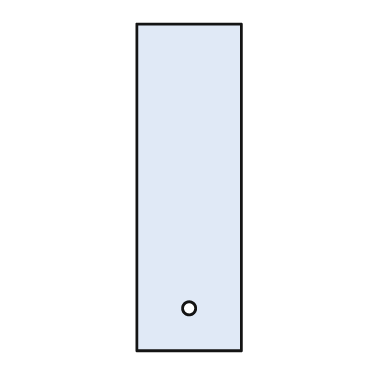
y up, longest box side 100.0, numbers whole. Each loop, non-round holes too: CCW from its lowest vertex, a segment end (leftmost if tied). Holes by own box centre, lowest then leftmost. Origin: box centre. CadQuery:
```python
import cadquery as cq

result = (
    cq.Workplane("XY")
    .moveTo(-16.0, -50.0)
    .lineTo(16.0, -50.0)
    .lineTo(16.0, 50.0)
    .lineTo(-16.0, 50.0)
    .close()
    .moveTo(0.0, -37.0)
    .circle(2.0)
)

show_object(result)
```